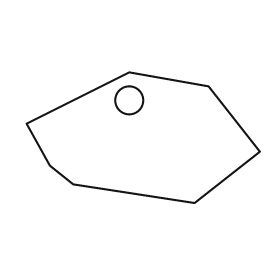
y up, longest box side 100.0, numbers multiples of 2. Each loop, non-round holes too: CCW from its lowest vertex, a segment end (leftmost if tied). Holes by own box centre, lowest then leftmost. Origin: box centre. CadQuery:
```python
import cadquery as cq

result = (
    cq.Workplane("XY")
    .moveTo(22.0, -28.0)
    .lineTo(50.0, -6.0)
    .lineTo(28.0, 22.0)
    .lineTo(-6.0, 28.0)
    .lineTo(-50.0, 6.0)
    .lineTo(-40.0, -12.0)
    .lineTo(-30.0, -20.0)
    .close()
    .moveTo(-6.0, 16.0)
    .circle(6.0)
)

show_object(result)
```